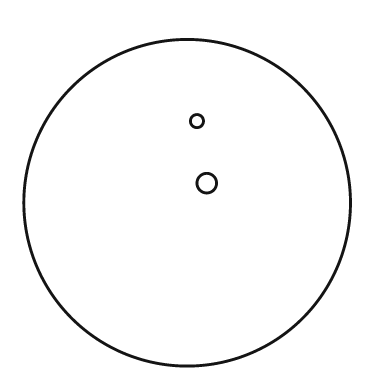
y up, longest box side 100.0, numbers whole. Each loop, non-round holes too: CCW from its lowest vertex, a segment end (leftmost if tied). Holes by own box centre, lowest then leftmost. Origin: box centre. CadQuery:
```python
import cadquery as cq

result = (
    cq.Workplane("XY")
    .moveTo(0.0, 0.0)
    .circle(50.0)
    .moveTo(6.0, 6.0)
    .circle(3.0)
    .moveTo(3.0, 25.0)
    .circle(2.0)
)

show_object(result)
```